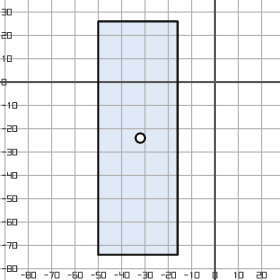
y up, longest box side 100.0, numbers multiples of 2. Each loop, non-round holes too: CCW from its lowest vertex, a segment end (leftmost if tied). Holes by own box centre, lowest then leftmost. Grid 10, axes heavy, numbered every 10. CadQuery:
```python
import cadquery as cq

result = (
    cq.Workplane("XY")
    .moveTo(-50.0, -74.0)
    .lineTo(-16.0, -74.0)
    .lineTo(-16.0, 26.0)
    .lineTo(-50.0, 26.0)
    .close()
    .moveTo(-32.0, -24.0)
    .circle(2.0)
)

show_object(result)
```